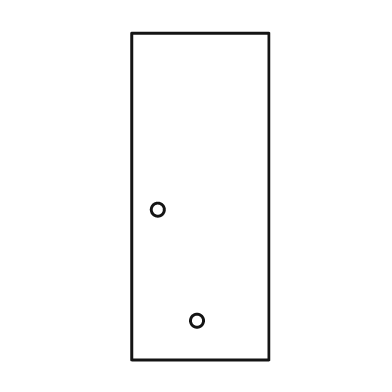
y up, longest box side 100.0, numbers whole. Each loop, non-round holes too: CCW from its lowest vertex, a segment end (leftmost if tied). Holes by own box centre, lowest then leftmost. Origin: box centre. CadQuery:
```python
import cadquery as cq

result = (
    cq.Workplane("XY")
    .moveTo(-21.0, -50.0)
    .lineTo(21.0, -50.0)
    .lineTo(21.0, 50.0)
    .lineTo(-21.0, 50.0)
    .close()
    .moveTo(-1.0, -38.0)
    .circle(2.0)
    .moveTo(-13.0, -4.0)
    .circle(2.0)
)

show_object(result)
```